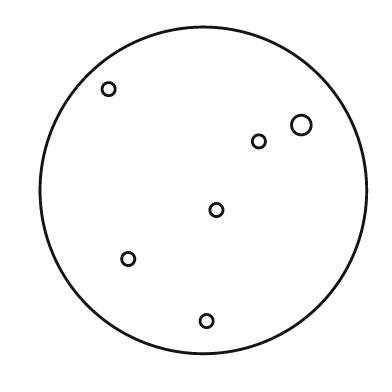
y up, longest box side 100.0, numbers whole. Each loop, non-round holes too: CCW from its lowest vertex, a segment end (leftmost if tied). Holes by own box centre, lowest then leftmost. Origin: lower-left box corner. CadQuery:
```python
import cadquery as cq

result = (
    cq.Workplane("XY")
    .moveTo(50.0, 50.0)
    .circle(50.0)
    .moveTo(51.0, 10.0)
    .circle(2.0)
    .moveTo(27.0, 29.0)
    .circle(2.0)
    .moveTo(54.0, 44.0)
    .circle(2.0)
    .moveTo(67.0, 65.0)
    .circle(2.0)
    .moveTo(80.0, 70.0)
    .circle(3.0)
    .moveTo(21.0, 81.0)
    .circle(2.0)
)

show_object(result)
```